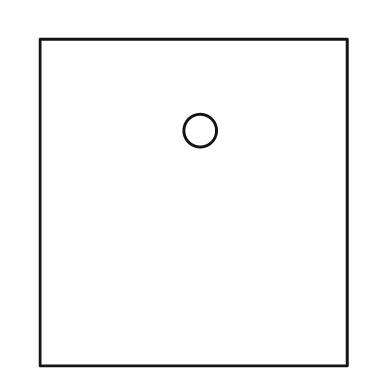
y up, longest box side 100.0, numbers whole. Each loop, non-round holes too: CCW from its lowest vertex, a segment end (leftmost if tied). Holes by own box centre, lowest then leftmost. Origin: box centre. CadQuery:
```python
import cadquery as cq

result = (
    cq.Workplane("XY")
    .moveTo(-47.0, -50.0)
    .lineTo(47.0, -50.0)
    .lineTo(47.0, 50.0)
    .lineTo(-47.0, 50.0)
    .close()
    .moveTo(2.0, 22.0)
    .circle(5.0)
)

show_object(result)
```